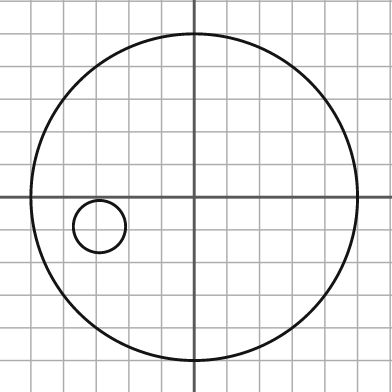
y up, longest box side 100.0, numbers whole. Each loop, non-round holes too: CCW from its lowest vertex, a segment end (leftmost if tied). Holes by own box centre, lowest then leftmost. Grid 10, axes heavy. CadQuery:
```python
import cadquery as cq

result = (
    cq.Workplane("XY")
    .moveTo(0.0, 0.0)
    .circle(50.0)
    .moveTo(-29.0, -9.0)
    .circle(8.0)
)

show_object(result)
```